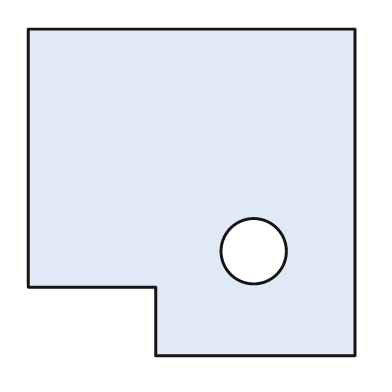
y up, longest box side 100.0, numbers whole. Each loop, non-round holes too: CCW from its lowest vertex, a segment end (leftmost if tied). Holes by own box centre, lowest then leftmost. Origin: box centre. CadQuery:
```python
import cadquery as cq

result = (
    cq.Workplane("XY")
    .moveTo(-11.0, -50.0)
    .lineTo(50.0, -50.0)
    .lineTo(50.0, 50.0)
    .lineTo(-50.0, 50.0)
    .lineTo(-50.0, -29.0)
    .lineTo(-11.0, -29.0)
    .close()
    .moveTo(19.0, -18.0)
    .circle(10.0)
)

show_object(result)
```